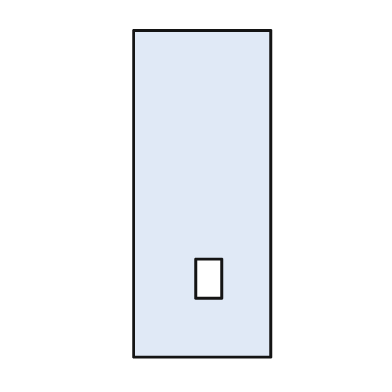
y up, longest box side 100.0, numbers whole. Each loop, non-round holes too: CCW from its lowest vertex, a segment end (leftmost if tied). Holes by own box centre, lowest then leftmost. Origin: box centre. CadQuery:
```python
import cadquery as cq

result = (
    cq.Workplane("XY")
    .moveTo(-21.0, -50.0)
    .lineTo(21.0, -50.0)
    .lineTo(21.0, 50.0)
    .lineTo(-21.0, 50.0)
    .close()
    .moveTo(-2.0, -32.0)
    .lineTo(6.0, -32.0)
    .lineTo(6.0, -20.0)
    .lineTo(-2.0, -20.0)
    .close()
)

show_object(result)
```